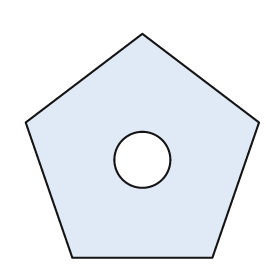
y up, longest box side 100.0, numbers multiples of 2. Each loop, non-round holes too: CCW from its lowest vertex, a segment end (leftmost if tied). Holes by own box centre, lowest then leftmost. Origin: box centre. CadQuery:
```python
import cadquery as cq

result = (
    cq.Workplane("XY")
    .moveTo(-30.0, -48.0)
    .lineTo(30.0, -48.0)
    .lineTo(50.0, 10.0)
    .lineTo(0.0, 48.0)
    .lineTo(-50.0, 10.0)
    .close()
    .moveTo(0.0, -6.0)
    .circle(12.0)
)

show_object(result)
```